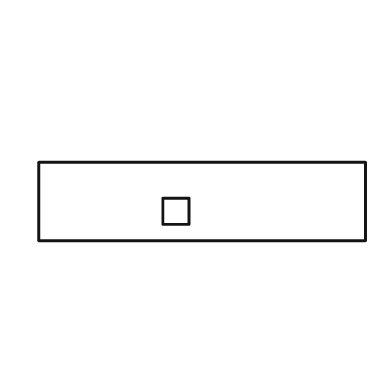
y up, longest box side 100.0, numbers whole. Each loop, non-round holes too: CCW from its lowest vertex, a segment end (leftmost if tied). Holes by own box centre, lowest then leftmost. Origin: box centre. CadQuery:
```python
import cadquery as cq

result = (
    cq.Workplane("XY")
    .moveTo(-50.0, -12.0)
    .lineTo(50.0, -12.0)
    .lineTo(50.0, 12.0)
    .lineTo(-50.0, 12.0)
    .close()
    .moveTo(-12.0, -7.0)
    .lineTo(-4.0, -7.0)
    .lineTo(-4.0, 1.0)
    .lineTo(-12.0, 1.0)
    .close()
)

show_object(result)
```